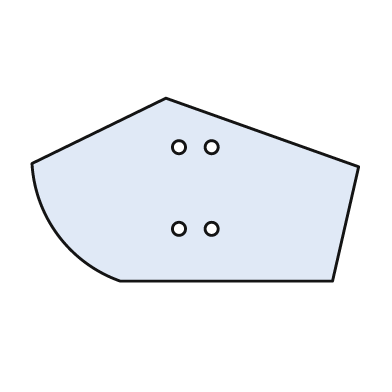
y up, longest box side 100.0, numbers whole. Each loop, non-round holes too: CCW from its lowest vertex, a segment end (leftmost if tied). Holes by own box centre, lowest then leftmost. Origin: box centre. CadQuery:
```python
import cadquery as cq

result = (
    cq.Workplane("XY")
    .moveTo(-23.0, -28.0)
    .lineTo(42.0, -28.0)
    .lineTo(50.0, 7.0)
    .lineTo(-9.0, 28.0)
    .lineTo(-50.0, 8.0)
    .threePointArc((-42.0, -14.0), (-23.0, -28.0))
    .close()
    .moveTo(-5.0, -12.0)
    .circle(2.0)
    .moveTo(5.0, -12.0)
    .circle(2.0)
    .moveTo(-5.0, 13.0)
    .circle(2.0)
    .moveTo(5.0, 13.0)
    .circle(2.0)
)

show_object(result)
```